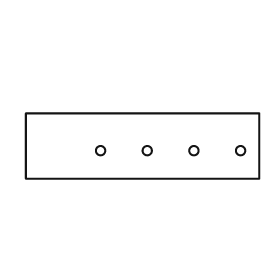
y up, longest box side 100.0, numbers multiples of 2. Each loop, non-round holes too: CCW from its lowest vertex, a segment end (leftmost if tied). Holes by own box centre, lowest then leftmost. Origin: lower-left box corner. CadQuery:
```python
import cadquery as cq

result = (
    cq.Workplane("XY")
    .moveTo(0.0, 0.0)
    .lineTo(100.0, 0.0)
    .lineTo(100.0, 28.0)
    .lineTo(0.0, 28.0)
    .close()
    .moveTo(32.0, 12.0)
    .circle(2.0)
    .moveTo(52.0, 12.0)
    .circle(2.0)
    .moveTo(72.0, 12.0)
    .circle(2.0)
    .moveTo(92.0, 12.0)
    .circle(2.0)
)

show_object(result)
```